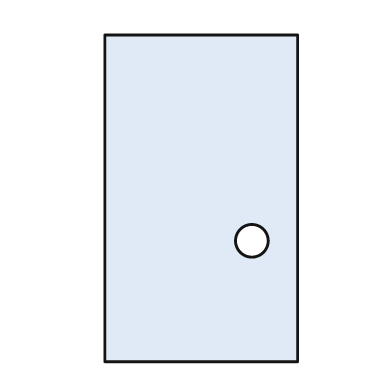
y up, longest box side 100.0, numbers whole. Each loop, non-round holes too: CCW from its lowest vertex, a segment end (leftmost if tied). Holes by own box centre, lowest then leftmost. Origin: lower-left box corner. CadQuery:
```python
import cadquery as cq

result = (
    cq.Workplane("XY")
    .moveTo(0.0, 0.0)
    .lineTo(59.0, 0.0)
    .lineTo(59.0, 100.0)
    .lineTo(0.0, 100.0)
    .close()
    .moveTo(45.0, 37.0)
    .circle(5.0)
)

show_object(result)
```